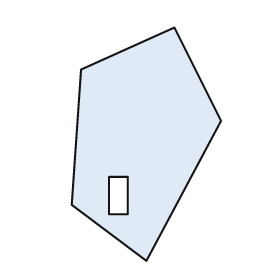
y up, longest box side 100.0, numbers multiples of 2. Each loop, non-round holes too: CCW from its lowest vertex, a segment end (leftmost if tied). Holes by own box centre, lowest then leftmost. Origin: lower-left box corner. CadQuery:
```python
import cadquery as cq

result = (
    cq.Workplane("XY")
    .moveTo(32.0, 0.0)
    .lineTo(64.0, 60.0)
    .lineTo(44.0, 100.0)
    .lineTo(4.0, 82.0)
    .lineTo(0.0, 24.0)
    .close()
    .moveTo(16.0, 20.0)
    .lineTo(24.0, 20.0)
    .lineTo(24.0, 36.0)
    .lineTo(16.0, 36.0)
    .close()
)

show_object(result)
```